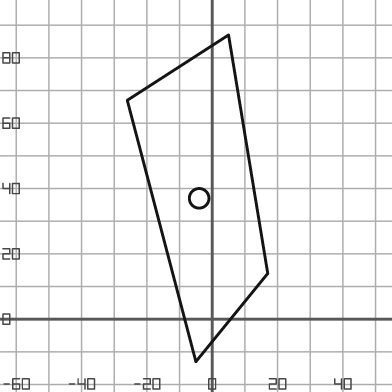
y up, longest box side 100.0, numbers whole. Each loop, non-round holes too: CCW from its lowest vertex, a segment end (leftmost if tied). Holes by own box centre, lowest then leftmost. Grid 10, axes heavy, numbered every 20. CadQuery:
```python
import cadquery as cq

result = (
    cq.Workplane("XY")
    .moveTo(-5.0, -13.0)
    .lineTo(17.0, 14.0)
    .lineTo(5.0, 87.0)
    .lineTo(-26.0, 67.0)
    .close()
    .moveTo(-4.0, 37.0)
    .circle(3.0)
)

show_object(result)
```